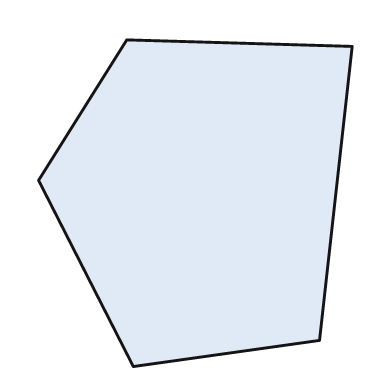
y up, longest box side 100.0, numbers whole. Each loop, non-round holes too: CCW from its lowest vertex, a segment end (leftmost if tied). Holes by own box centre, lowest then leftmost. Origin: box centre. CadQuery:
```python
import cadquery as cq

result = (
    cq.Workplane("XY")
    .moveTo(-19.0, -50.0)
    .lineTo(38.0, -42.0)
    .lineTo(48.0, 48.0)
    .lineTo(-21.0, 50.0)
    .lineTo(-48.0, 7.0)
    .close()
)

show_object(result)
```